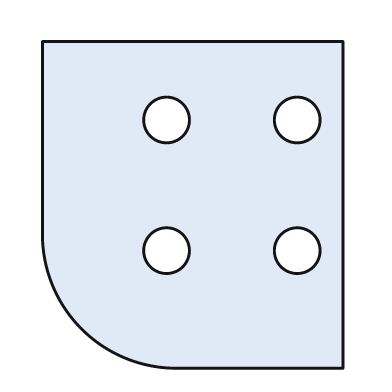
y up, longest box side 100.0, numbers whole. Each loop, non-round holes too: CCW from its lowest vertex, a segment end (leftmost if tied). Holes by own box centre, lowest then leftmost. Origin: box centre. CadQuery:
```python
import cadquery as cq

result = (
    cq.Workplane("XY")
    .moveTo(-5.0, -50.0)
    .lineTo(46.0, -50.0)
    .lineTo(46.0, 50.0)
    .lineTo(-46.0, 50.0)
    .lineTo(-46.0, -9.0)
    .threePointArc((-34.0, -38.0), (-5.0, -50.0))
    .close()
    .moveTo(-8.0, -14.0)
    .circle(7.0)
    .moveTo(32.0, -14.0)
    .circle(7.0)
    .moveTo(-8.0, 26.0)
    .circle(7.0)
    .moveTo(32.0, 26.0)
    .circle(7.0)
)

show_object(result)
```